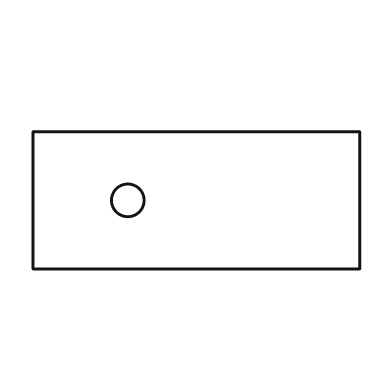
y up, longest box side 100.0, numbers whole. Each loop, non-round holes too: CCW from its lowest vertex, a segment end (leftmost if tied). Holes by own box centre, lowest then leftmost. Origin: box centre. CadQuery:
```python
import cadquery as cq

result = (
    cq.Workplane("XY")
    .moveTo(-50.0, -21.0)
    .lineTo(50.0, -21.0)
    .lineTo(50.0, 21.0)
    .lineTo(-50.0, 21.0)
    .close()
    .moveTo(-21.0, 0.0)
    .circle(5.0)
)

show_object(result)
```